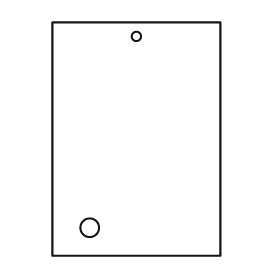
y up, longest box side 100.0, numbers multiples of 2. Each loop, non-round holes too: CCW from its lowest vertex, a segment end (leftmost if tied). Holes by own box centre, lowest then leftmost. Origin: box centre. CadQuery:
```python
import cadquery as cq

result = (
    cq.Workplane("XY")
    .moveTo(-36.0, -50.0)
    .lineTo(36.0, -50.0)
    .lineTo(36.0, 50.0)
    .lineTo(-36.0, 50.0)
    .close()
    .moveTo(-20.0, -38.0)
    .circle(4.0)
    .moveTo(0.0, 44.0)
    .circle(2.0)
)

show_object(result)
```